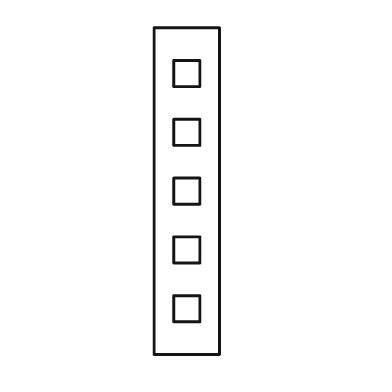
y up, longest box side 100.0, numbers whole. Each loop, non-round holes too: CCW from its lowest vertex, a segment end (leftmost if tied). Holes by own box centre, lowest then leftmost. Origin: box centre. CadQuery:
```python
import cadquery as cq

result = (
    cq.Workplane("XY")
    .moveTo(-10.0, -50.0)
    .lineTo(10.0, -50.0)
    .lineTo(10.0, 50.0)
    .lineTo(-10.0, 50.0)
    .close()
    .moveTo(-4.0, -40.0)
    .lineTo(4.0, -40.0)
    .lineTo(4.0, -32.0)
    .lineTo(-4.0, -32.0)
    .close()
    .moveTo(-4.0, -22.0)
    .lineTo(4.0, -22.0)
    .lineTo(4.0, -14.0)
    .lineTo(-4.0, -14.0)
    .close()
    .moveTo(-4.0, -4.0)
    .lineTo(4.0, -4.0)
    .lineTo(4.0, 4.0)
    .lineTo(-4.0, 4.0)
    .close()
    .moveTo(-4.0, 14.0)
    .lineTo(4.0, 14.0)
    .lineTo(4.0, 22.0)
    .lineTo(-4.0, 22.0)
    .close()
    .moveTo(-4.0, 32.0)
    .lineTo(4.0, 32.0)
    .lineTo(4.0, 40.0)
    .lineTo(-4.0, 40.0)
    .close()
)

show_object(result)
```